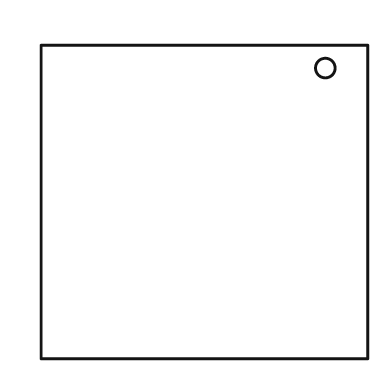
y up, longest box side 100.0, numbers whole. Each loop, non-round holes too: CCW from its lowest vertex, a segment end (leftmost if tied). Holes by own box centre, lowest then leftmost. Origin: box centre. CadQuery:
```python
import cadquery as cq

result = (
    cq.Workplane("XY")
    .moveTo(-50.0, -48.0)
    .lineTo(50.0, -48.0)
    .lineTo(50.0, 48.0)
    .lineTo(-50.0, 48.0)
    .close()
    .moveTo(37.0, 41.0)
    .circle(3.0)
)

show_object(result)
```